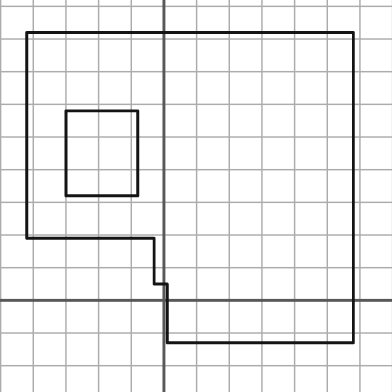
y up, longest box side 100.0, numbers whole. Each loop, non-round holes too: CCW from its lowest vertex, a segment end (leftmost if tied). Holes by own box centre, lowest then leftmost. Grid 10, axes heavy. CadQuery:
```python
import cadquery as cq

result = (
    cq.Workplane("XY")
    .moveTo(1.0, -13.0)
    .lineTo(58.0, -13.0)
    .lineTo(58.0, 82.0)
    .lineTo(-42.0, 82.0)
    .lineTo(-42.0, 19.0)
    .lineTo(-3.0, 19.0)
    .lineTo(-3.0, 5.0)
    .lineTo(1.0, 5.0)
    .close()
    .moveTo(-30.0, 32.0)
    .lineTo(-8.0, 32.0)
    .lineTo(-8.0, 58.0)
    .lineTo(-30.0, 58.0)
    .close()
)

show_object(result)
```